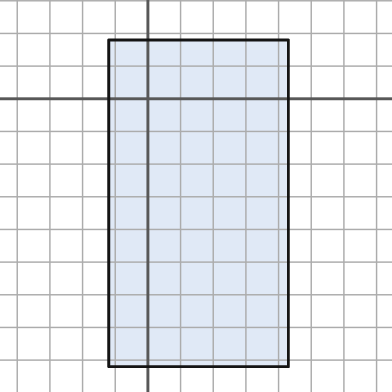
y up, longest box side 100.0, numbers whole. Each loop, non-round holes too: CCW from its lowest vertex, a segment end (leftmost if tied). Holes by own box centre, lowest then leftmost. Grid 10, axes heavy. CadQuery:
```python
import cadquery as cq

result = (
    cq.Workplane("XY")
    .moveTo(-12.0, -82.0)
    .lineTo(43.0, -82.0)
    .lineTo(43.0, 18.0)
    .lineTo(-12.0, 18.0)
    .close()
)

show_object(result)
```